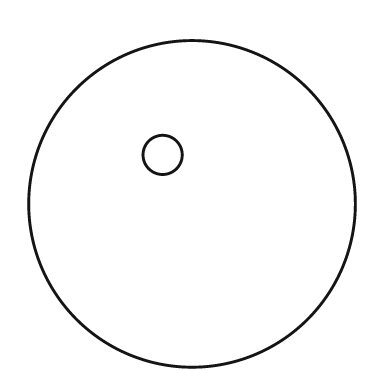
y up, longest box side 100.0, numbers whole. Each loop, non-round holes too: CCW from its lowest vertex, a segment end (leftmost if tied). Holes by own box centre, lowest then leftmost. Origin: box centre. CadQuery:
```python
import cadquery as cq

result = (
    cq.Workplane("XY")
    .moveTo(0.0, 0.0)
    .circle(50.0)
    .moveTo(-9.0, 15.0)
    .circle(6.0)
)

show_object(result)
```